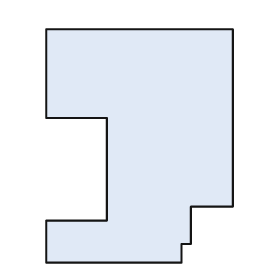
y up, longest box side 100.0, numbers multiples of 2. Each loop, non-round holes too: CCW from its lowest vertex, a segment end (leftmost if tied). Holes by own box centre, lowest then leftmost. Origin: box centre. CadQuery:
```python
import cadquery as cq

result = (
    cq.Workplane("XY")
    .moveTo(-40.0, -50.0)
    .lineTo(18.0, -50.0)
    .lineTo(18.0, -42.0)
    .lineTo(22.0, -42.0)
    .lineTo(22.0, -26.0)
    .lineTo(40.0, -26.0)
    .lineTo(40.0, 50.0)
    .lineTo(-40.0, 50.0)
    .lineTo(-40.0, 12.0)
    .lineTo(-14.0, 12.0)
    .lineTo(-14.0, -32.0)
    .lineTo(-40.0, -32.0)
    .close()
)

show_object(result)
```